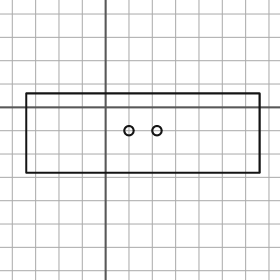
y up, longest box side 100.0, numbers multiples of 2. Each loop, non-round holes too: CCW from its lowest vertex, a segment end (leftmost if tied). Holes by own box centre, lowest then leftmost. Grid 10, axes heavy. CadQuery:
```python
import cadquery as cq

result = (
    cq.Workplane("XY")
    .moveTo(-34.0, -28.0)
    .lineTo(66.0, -28.0)
    .lineTo(66.0, 6.0)
    .lineTo(-34.0, 6.0)
    .close()
    .moveTo(10.0, -10.0)
    .circle(2.0)
    .moveTo(22.0, -10.0)
    .circle(2.0)
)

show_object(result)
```